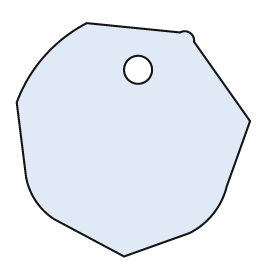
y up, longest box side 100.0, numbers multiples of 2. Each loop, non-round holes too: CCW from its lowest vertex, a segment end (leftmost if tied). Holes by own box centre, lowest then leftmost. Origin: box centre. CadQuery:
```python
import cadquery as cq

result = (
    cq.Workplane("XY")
    .moveTo(-4.0, -50.0)
    .lineTo(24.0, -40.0)
    .threePointArc((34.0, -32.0), (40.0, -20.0))
    .lineTo(50.0, 8.0)
    .lineTo(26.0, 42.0)
    .threePointArc((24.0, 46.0), (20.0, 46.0))
    .lineTo(-20.0, 50.0)
    .threePointArc((-38.0, 36.0), (-50.0, 16.0))
    .lineTo(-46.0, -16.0)
    .threePointArc((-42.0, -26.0), (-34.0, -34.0))
    .close()
    .moveTo(2.0, 30.0)
    .circle(6.0)
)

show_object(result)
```